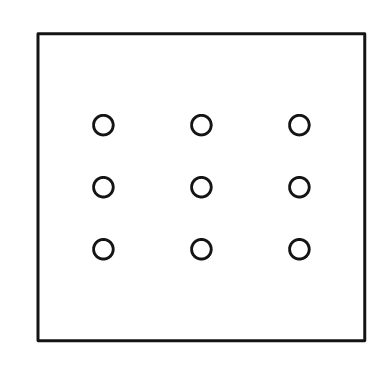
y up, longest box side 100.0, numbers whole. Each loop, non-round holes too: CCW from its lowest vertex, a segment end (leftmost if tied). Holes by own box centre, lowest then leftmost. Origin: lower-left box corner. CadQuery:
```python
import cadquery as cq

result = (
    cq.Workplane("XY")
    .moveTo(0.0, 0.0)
    .lineTo(100.0, 0.0)
    .lineTo(100.0, 94.0)
    .lineTo(0.0, 94.0)
    .close()
    .moveTo(20.0, 28.0)
    .circle(3.0)
    .moveTo(50.0, 28.0)
    .circle(3.0)
    .moveTo(80.0, 28.0)
    .circle(3.0)
    .moveTo(20.0, 47.0)
    .circle(3.0)
    .moveTo(50.0, 47.0)
    .circle(3.0)
    .moveTo(80.0, 47.0)
    .circle(3.0)
    .moveTo(20.0, 66.0)
    .circle(3.0)
    .moveTo(50.0, 66.0)
    .circle(3.0)
    .moveTo(80.0, 66.0)
    .circle(3.0)
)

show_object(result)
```